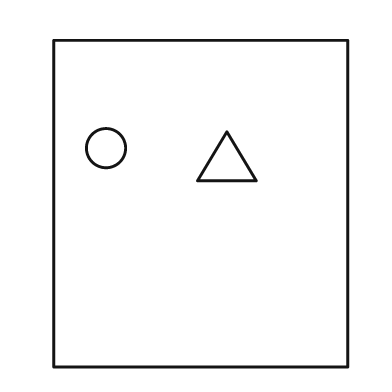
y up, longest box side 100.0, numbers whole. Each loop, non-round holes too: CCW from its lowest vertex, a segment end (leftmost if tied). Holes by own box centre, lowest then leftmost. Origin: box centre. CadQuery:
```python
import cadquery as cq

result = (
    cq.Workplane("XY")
    .moveTo(-45.0, -50.0)
    .lineTo(45.0, -50.0)
    .lineTo(45.0, 50.0)
    .lineTo(-45.0, 50.0)
    .close()
    .moveTo(-1.0, 7.0)
    .lineTo(17.0, 7.0)
    .lineTo(8.0, 22.0)
    .close()
    .moveTo(-29.0, 17.0)
    .circle(6.0)
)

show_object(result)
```